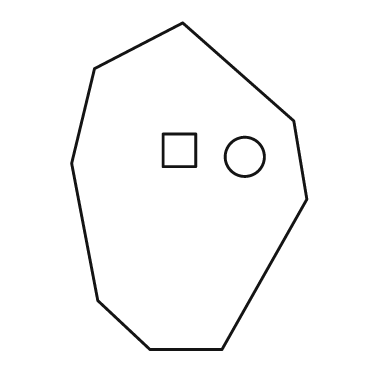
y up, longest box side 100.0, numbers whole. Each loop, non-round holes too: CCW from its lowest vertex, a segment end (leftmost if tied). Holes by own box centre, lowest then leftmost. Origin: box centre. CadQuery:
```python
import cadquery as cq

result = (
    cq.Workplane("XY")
    .moveTo(-12.0, -50.0)
    .lineTo(10.0, -50.0)
    .lineTo(36.0, -4.0)
    .lineTo(32.0, 20.0)
    .lineTo(-2.0, 50.0)
    .lineTo(-29.0, 36.0)
    .lineTo(-36.0, 7.0)
    .lineTo(-28.0, -35.0)
    .close()
    .moveTo(17.0, 9.0)
    .circle(6.0)
    .moveTo(-8.0, 6.0)
    .lineTo(2.0, 6.0)
    .lineTo(2.0, 16.0)
    .lineTo(-8.0, 16.0)
    .close()
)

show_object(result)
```